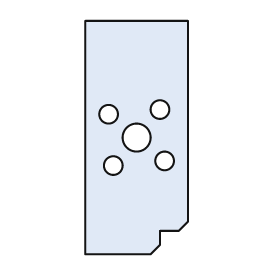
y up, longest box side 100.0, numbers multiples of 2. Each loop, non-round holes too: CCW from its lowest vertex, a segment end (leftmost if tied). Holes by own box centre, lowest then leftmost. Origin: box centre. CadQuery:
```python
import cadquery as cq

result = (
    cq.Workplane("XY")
    .moveTo(-22.0, -50.0)
    .lineTo(6.0, -50.0)
    .lineTo(10.0, -46.0)
    .lineTo(10.0, -40.0)
    .lineTo(18.0, -40.0)
    .lineTo(22.0, -36.0)
    .lineTo(22.0, 50.0)
    .lineTo(-22.0, 50.0)
    .close()
    .moveTo(-10.0, -12.0)
    .circle(4.0)
    .moveTo(12.0, -10.0)
    .circle(4.0)
    .moveTo(0.0, 0.0)
    .circle(6.0)
    .moveTo(-12.0, 10.0)
    .circle(4.0)
    .moveTo(10.0, 12.0)
    .circle(4.0)
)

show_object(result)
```